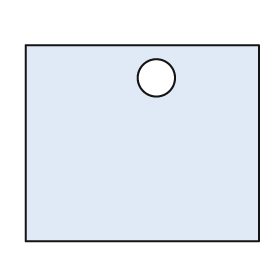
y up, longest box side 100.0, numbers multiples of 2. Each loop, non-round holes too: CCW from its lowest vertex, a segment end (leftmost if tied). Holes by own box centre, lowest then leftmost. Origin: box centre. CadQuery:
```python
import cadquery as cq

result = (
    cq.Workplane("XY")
    .moveTo(-50.0, -42.0)
    .lineTo(50.0, -42.0)
    .lineTo(50.0, 42.0)
    .lineTo(-50.0, 42.0)
    .close()
    .moveTo(6.0, 28.0)
    .circle(8.0)
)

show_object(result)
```